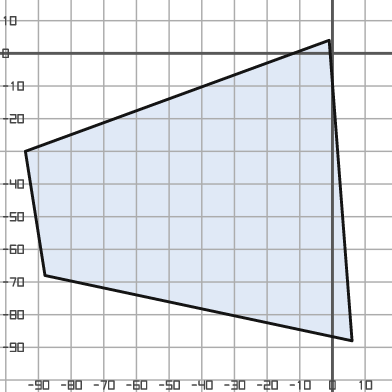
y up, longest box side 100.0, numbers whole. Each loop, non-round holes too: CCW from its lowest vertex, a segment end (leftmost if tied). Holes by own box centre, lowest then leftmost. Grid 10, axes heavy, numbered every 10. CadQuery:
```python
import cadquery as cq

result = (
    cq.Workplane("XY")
    .moveTo(6.0, -88.0)
    .lineTo(-1.0, 4.0)
    .lineTo(-94.0, -30.0)
    .lineTo(-88.0, -68.0)
    .close()
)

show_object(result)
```